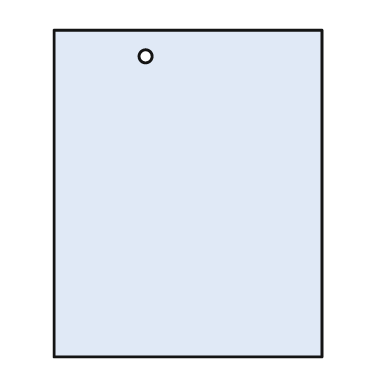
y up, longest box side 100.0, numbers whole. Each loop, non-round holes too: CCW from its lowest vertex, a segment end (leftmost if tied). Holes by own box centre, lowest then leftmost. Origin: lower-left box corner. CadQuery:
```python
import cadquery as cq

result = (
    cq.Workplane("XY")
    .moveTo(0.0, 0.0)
    .lineTo(82.0, 0.0)
    .lineTo(82.0, 100.0)
    .lineTo(0.0, 100.0)
    .close()
    .moveTo(28.0, 92.0)
    .circle(2.0)
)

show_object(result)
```